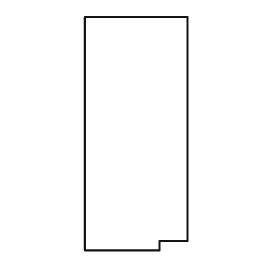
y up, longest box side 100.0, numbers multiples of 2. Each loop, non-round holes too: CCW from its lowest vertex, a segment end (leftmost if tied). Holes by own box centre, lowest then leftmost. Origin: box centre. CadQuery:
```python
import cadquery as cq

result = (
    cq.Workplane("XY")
    .moveTo(-22.0, -50.0)
    .lineTo(10.0, -50.0)
    .lineTo(10.0, -46.0)
    .lineTo(22.0, -46.0)
    .lineTo(22.0, 50.0)
    .lineTo(-22.0, 50.0)
    .close()
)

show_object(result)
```